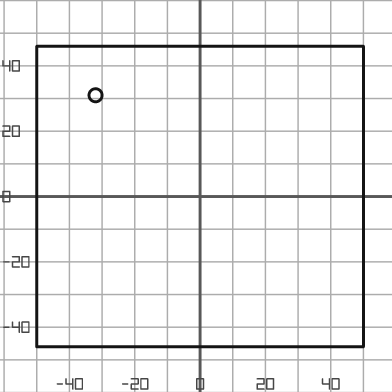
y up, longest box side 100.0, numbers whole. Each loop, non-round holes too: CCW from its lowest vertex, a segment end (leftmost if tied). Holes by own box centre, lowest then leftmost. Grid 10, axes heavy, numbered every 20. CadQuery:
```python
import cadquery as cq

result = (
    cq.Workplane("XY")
    .moveTo(-50.0, -46.0)
    .lineTo(50.0, -46.0)
    .lineTo(50.0, 46.0)
    .lineTo(-50.0, 46.0)
    .close()
    .moveTo(-32.0, 31.0)
    .circle(2.0)
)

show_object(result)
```